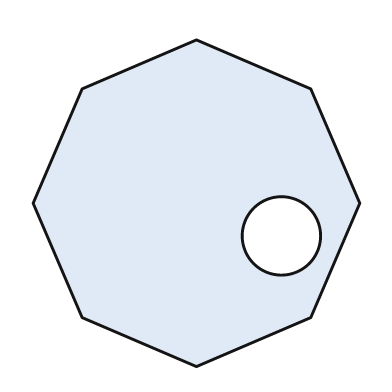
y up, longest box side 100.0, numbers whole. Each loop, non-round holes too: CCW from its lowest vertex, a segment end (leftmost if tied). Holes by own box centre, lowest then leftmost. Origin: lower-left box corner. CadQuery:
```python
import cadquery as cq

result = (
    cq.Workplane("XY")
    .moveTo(50.0, 0.0)
    .lineTo(85.0, 15.0)
    .lineTo(100.0, 50.0)
    .lineTo(85.0, 85.0)
    .lineTo(50.0, 100.0)
    .lineTo(15.0, 85.0)
    .lineTo(0.0, 50.0)
    .lineTo(15.0, 15.0)
    .close()
    .moveTo(76.0, 40.0)
    .circle(12.0)
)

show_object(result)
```